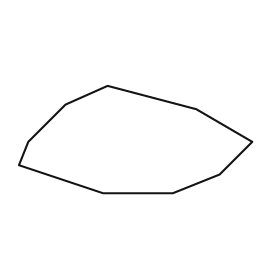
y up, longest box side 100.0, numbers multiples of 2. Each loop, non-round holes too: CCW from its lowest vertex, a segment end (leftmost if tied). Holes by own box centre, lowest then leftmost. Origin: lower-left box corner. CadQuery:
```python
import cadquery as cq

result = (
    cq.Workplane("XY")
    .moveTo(36.0, 0.0)
    .lineTo(66.0, 0.0)
    .lineTo(86.0, 8.0)
    .lineTo(100.0, 22.0)
    .lineTo(76.0, 36.0)
    .lineTo(38.0, 46.0)
    .lineTo(20.0, 38.0)
    .lineTo(4.0, 22.0)
    .lineTo(0.0, 12.0)
    .close()
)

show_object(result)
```